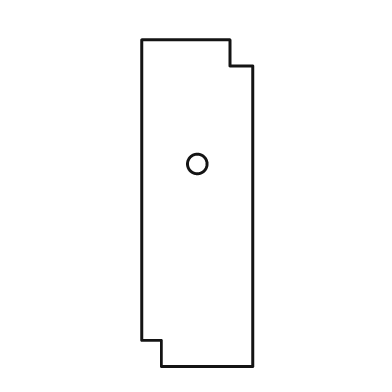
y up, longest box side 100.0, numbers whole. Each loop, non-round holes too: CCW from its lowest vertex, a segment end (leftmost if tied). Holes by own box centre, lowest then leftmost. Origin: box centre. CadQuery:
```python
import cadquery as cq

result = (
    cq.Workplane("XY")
    .moveTo(-11.0, -50.0)
    .lineTo(17.0, -50.0)
    .lineTo(17.0, 42.0)
    .lineTo(10.0, 42.0)
    .lineTo(10.0, 50.0)
    .lineTo(-17.0, 50.0)
    .lineTo(-17.0, -42.0)
    .lineTo(-11.0, -42.0)
    .close()
    .moveTo(0.0, 12.0)
    .circle(3.0)
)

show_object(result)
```